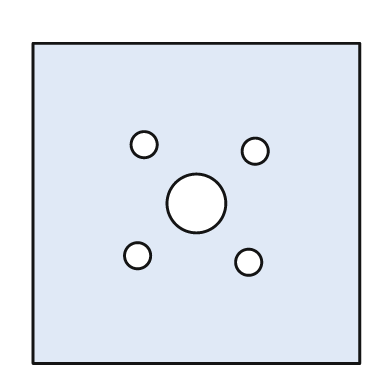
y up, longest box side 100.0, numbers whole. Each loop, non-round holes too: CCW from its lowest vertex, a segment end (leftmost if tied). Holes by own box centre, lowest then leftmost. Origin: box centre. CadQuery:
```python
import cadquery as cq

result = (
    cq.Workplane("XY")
    .moveTo(-50.0, -49.0)
    .lineTo(50.0, -49.0)
    .lineTo(50.0, 49.0)
    .lineTo(-50.0, 49.0)
    .close()
    .moveTo(16.0, -18.0)
    .circle(4.0)
    .moveTo(-18.0, -16.0)
    .circle(4.0)
    .moveTo(0.0, 0.0)
    .circle(9.0)
    .moveTo(18.0, 16.0)
    .circle(4.0)
    .moveTo(-16.0, 18.0)
    .circle(4.0)
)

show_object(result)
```